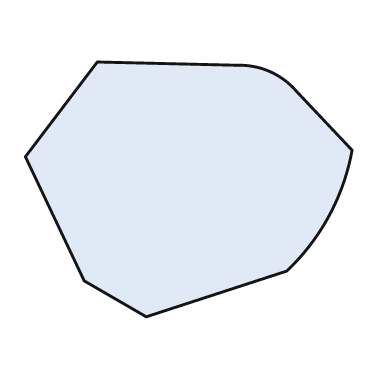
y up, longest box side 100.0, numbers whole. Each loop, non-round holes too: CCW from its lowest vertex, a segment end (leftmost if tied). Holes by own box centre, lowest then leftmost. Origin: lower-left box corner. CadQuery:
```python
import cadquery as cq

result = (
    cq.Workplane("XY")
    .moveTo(37.0, 0.0)
    .lineTo(80.0, 14.0)
    .threePointArc((93.0, 31.0), (100.0, 51.0))
    .lineTo(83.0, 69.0)
    .threePointArc((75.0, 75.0), (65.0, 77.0))
    .lineTo(22.0, 78.0)
    .lineTo(0.0, 49.0)
    .lineTo(18.0, 11.0)
    .close()
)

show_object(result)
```